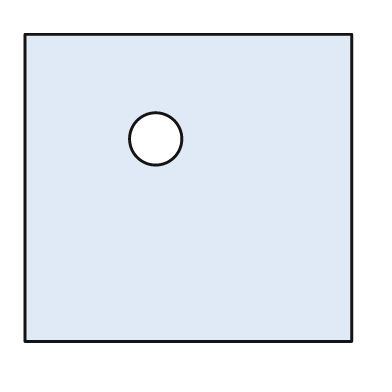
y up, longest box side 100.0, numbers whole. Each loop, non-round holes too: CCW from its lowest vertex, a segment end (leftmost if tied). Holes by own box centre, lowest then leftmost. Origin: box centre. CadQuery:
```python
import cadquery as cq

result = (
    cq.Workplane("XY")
    .moveTo(-50.0, -47.0)
    .lineTo(50.0, -47.0)
    .lineTo(50.0, 47.0)
    .lineTo(-50.0, 47.0)
    .close()
    .moveTo(-10.0, 15.0)
    .circle(8.0)
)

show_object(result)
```